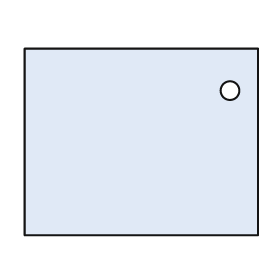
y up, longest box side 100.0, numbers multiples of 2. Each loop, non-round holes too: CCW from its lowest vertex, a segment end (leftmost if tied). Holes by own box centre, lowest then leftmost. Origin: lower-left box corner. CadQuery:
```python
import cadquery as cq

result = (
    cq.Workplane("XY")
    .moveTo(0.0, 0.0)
    .lineTo(100.0, 0.0)
    .lineTo(100.0, 80.0)
    .lineTo(0.0, 80.0)
    .close()
    .moveTo(88.0, 62.0)
    .circle(4.0)
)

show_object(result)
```